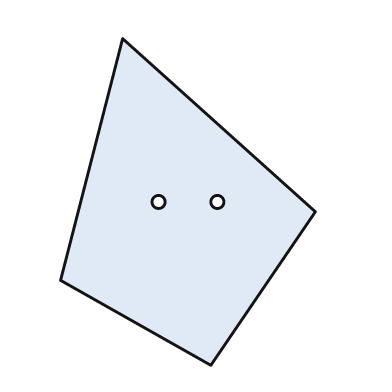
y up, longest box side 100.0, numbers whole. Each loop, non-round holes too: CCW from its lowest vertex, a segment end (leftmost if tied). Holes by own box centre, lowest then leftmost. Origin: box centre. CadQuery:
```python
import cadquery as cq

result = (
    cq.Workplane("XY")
    .moveTo(7.0, -50.0)
    .lineTo(39.0, -3.0)
    .lineTo(-20.0, 50.0)
    .lineTo(-39.0, -24.0)
    .close()
    .moveTo(-9.0, 0.0)
    .circle(2.0)
    .moveTo(9.0, 0.0)
    .circle(2.0)
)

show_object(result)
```